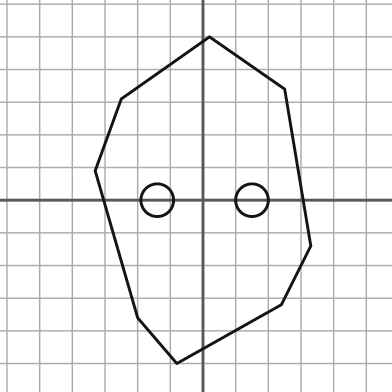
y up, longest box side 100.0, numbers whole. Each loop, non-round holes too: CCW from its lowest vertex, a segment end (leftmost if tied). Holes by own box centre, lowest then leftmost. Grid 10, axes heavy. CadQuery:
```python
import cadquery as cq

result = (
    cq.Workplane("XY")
    .moveTo(-8.0, -50.0)
    .lineTo(24.0, -32.0)
    .lineTo(33.0, -14.0)
    .lineTo(25.0, 34.0)
    .lineTo(2.0, 50.0)
    .lineTo(-25.0, 31.0)
    .lineTo(-33.0, 9.0)
    .lineTo(-20.0, -36.0)
    .close()
    .moveTo(-14.0, 0.0)
    .circle(5.0)
    .moveTo(15.0, 0.0)
    .circle(5.0)
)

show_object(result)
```